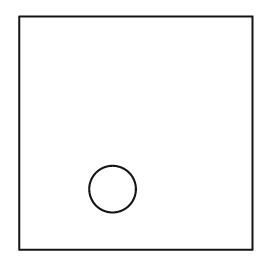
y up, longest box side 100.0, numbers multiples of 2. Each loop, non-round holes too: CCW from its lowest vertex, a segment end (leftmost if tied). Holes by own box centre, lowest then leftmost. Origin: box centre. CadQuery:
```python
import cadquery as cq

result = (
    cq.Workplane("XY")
    .moveTo(-50.0, -50.0)
    .lineTo(50.0, -50.0)
    .lineTo(50.0, 50.0)
    .lineTo(-50.0, 50.0)
    .close()
    .moveTo(-10.0, -24.0)
    .circle(10.0)
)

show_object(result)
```